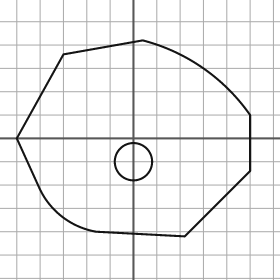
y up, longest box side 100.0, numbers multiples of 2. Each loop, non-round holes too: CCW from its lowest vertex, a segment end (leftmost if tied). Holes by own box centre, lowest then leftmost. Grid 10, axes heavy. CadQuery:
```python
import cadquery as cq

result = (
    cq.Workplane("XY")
    .moveTo(22.0, -42.0)
    .lineTo(50.0, -14.0)
    .lineTo(50.0, 10.0)
    .threePointArc((30.0, 30.0), (4.0, 42.0))
    .lineTo(-30.0, 36.0)
    .lineTo(-50.0, 0.0)
    .lineTo(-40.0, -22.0)
    .threePointArc((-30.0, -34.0), (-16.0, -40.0))
    .close()
    .moveTo(0.0, -10.0)
    .circle(8.0)
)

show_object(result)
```